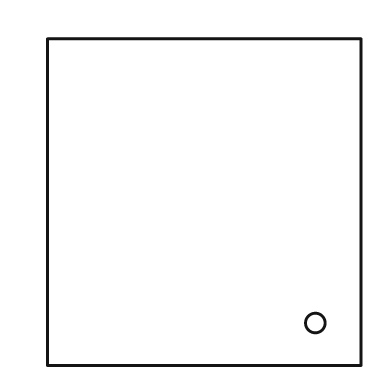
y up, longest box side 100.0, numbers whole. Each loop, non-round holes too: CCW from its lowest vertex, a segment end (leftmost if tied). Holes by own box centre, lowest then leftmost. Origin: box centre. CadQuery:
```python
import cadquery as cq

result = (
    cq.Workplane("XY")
    .moveTo(-48.0, -50.0)
    .lineTo(48.0, -50.0)
    .lineTo(48.0, 50.0)
    .lineTo(-48.0, 50.0)
    .close()
    .moveTo(34.0, -37.0)
    .circle(3.0)
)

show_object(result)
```